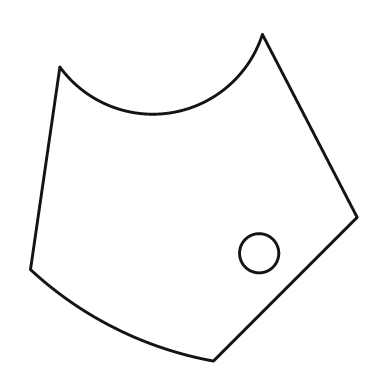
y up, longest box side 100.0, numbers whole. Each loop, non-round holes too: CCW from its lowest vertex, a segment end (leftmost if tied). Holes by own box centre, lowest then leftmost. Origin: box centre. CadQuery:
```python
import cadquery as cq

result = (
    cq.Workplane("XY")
    .moveTo(6.0, -50.0)
    .lineTo(50.0, -6.0)
    .lineTo(21.0, 50.0)
    .threePointArc((-7.0, 26.0), (-41.0, 40.0))
    .lineTo(-50.0, -22.0)
    .threePointArc((-24.0, -40.0), (6.0, -50.0))
    .close()
    .moveTo(20.0, -17.0)
    .circle(6.0)
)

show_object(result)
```